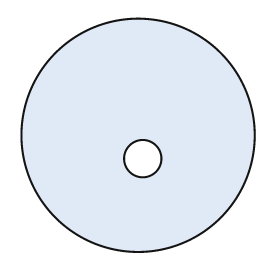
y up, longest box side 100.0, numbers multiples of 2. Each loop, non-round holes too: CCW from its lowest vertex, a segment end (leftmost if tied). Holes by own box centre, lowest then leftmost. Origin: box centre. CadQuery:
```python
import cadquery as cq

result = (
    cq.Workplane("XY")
    .moveTo(0.0, 0.0)
    .circle(50.0)
    .moveTo(2.0, -10.0)
    .circle(8.0)
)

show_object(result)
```